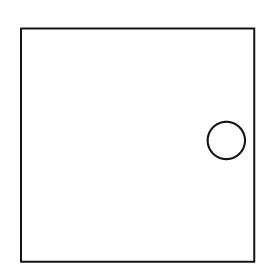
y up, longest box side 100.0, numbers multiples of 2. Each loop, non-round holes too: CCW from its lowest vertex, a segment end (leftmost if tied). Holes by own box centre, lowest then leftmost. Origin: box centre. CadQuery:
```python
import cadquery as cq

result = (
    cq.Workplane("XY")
    .moveTo(-50.0, -50.0)
    .lineTo(50.0, -50.0)
    .lineTo(50.0, 50.0)
    .lineTo(-50.0, 50.0)
    .close()
    .moveTo(38.0, 2.0)
    .circle(8.0)
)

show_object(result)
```